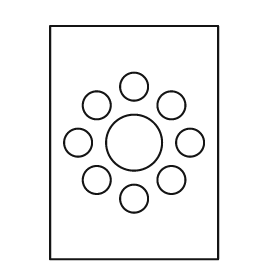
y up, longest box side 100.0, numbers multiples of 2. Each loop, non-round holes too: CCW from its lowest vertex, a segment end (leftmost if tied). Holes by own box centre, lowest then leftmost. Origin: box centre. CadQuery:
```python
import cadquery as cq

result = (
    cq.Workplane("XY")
    .moveTo(-36.0, -50.0)
    .lineTo(36.0, -50.0)
    .lineTo(36.0, 50.0)
    .lineTo(-36.0, 50.0)
    .close()
    .moveTo(0.0, -24.0)
    .circle(6.0)
    .moveTo(-16.0, -16.0)
    .circle(6.0)
    .moveTo(16.0, -16.0)
    .circle(6.0)
    .moveTo(-24.0, 0.0)
    .circle(6.0)
    .moveTo(0.0, 0.0)
    .circle(12.0)
    .moveTo(24.0, 0.0)
    .circle(6.0)
    .moveTo(-16.0, 16.0)
    .circle(6.0)
    .moveTo(16.0, 16.0)
    .circle(6.0)
    .moveTo(0.0, 24.0)
    .circle(6.0)
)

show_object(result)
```